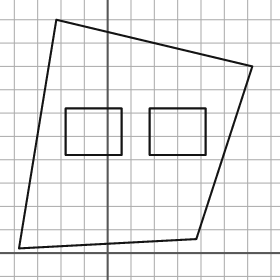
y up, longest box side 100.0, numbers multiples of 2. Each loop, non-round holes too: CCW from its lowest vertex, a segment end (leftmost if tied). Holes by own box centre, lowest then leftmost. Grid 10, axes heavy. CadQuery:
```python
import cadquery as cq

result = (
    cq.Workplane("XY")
    .moveTo(-38.0, 2.0)
    .lineTo(38.0, 6.0)
    .lineTo(62.0, 80.0)
    .lineTo(-22.0, 100.0)
    .close()
    .moveTo(-18.0, 42.0)
    .lineTo(6.0, 42.0)
    .lineTo(6.0, 62.0)
    .lineTo(-18.0, 62.0)
    .close()
    .moveTo(18.0, 42.0)
    .lineTo(42.0, 42.0)
    .lineTo(42.0, 62.0)
    .lineTo(18.0, 62.0)
    .close()
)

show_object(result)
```